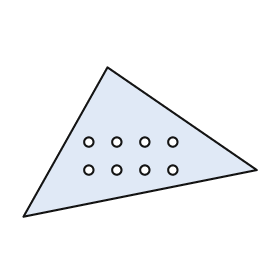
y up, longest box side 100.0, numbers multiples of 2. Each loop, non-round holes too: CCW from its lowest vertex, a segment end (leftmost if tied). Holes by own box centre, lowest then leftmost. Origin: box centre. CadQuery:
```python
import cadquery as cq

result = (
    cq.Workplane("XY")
    .moveTo(-50.0, -32.0)
    .lineTo(50.0, -12.0)
    .lineTo(-14.0, 32.0)
    .close()
    .moveTo(-22.0, -12.0)
    .circle(2.0)
    .moveTo(-10.0, -12.0)
    .circle(2.0)
    .moveTo(2.0, -12.0)
    .circle(2.0)
    .moveTo(14.0, -12.0)
    .circle(2.0)
    .moveTo(-22.0, 0.0)
    .circle(2.0)
    .moveTo(-10.0, 0.0)
    .circle(2.0)
    .moveTo(2.0, 0.0)
    .circle(2.0)
    .moveTo(14.0, 0.0)
    .circle(2.0)
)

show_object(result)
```